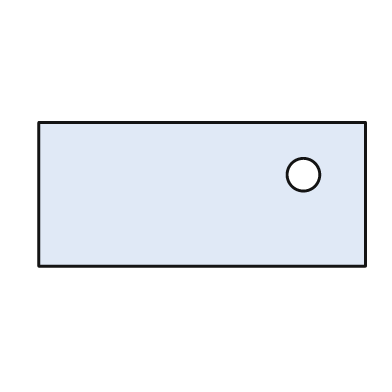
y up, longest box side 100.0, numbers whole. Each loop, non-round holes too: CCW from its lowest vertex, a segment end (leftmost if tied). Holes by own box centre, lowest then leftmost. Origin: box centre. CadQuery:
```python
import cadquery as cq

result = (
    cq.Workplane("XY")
    .moveTo(-50.0, -22.0)
    .lineTo(50.0, -22.0)
    .lineTo(50.0, 22.0)
    .lineTo(-50.0, 22.0)
    .close()
    .moveTo(31.0, 6.0)
    .circle(5.0)
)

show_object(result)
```